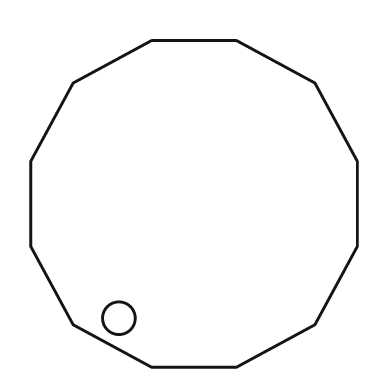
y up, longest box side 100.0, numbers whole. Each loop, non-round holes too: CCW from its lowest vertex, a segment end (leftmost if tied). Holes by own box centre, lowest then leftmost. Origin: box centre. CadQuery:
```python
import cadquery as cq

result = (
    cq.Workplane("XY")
    .moveTo(-13.0, -50.0)
    .lineTo(13.0, -50.0)
    .lineTo(37.0, -37.0)
    .lineTo(50.0, -13.0)
    .lineTo(50.0, 13.0)
    .lineTo(37.0, 37.0)
    .lineTo(13.0, 50.0)
    .lineTo(-13.0, 50.0)
    .lineTo(-37.0, 37.0)
    .lineTo(-50.0, 13.0)
    .lineTo(-50.0, -13.0)
    .lineTo(-37.0, -37.0)
    .close()
    .moveTo(-23.0, -35.0)
    .circle(5.0)
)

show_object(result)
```